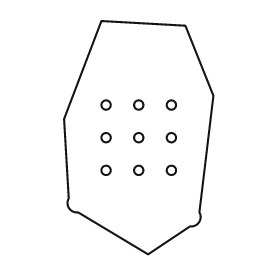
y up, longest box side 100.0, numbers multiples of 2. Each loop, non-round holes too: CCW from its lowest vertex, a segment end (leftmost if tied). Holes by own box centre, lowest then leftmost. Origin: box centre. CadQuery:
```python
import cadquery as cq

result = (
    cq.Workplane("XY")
    .moveTo(4.0, -50.0)
    .lineTo(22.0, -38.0)
    .threePointArc((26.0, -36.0), (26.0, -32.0))
    .lineTo(32.0, 18.0)
    .lineTo(20.0, 48.0)
    .lineTo(-16.0, 50.0)
    .lineTo(-32.0, 8.0)
    .lineTo(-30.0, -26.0)
    .threePointArc((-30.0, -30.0), (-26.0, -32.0))
    .close()
    .moveTo(-14.0, -14.0)
    .circle(2.0)
    .moveTo(0.0, -14.0)
    .circle(2.0)
    .moveTo(14.0, -14.0)
    .circle(2.0)
    .moveTo(-14.0, 0.0)
    .circle(2.0)
    .moveTo(0.0, 0.0)
    .circle(2.0)
    .moveTo(14.0, 0.0)
    .circle(2.0)
    .moveTo(-14.0, 14.0)
    .circle(2.0)
    .moveTo(0.0, 14.0)
    .circle(2.0)
    .moveTo(14.0, 14.0)
    .circle(2.0)
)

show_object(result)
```